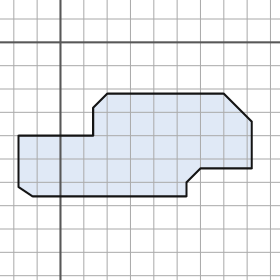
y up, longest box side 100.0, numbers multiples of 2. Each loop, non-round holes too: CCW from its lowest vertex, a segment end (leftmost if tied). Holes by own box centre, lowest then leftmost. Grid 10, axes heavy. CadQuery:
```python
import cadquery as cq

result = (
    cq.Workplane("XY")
    .moveTo(-12.0, -66.0)
    .lineTo(54.0, -66.0)
    .lineTo(54.0, -60.0)
    .lineTo(60.0, -54.0)
    .lineTo(82.0, -54.0)
    .lineTo(82.0, -34.0)
    .lineTo(70.0, -22.0)
    .lineTo(20.0, -22.0)
    .lineTo(14.0, -28.0)
    .lineTo(14.0, -40.0)
    .lineTo(-18.0, -40.0)
    .lineTo(-18.0, -62.0)
    .close()
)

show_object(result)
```